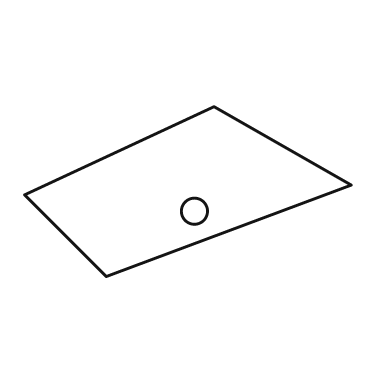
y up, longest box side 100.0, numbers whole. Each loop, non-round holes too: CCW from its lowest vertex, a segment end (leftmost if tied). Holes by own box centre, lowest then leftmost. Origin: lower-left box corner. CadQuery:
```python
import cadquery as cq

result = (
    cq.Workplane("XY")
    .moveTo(25.0, 0.0)
    .lineTo(100.0, 28.0)
    .lineTo(58.0, 52.0)
    .lineTo(0.0, 25.0)
    .close()
    .moveTo(52.0, 20.0)
    .circle(4.0)
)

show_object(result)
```